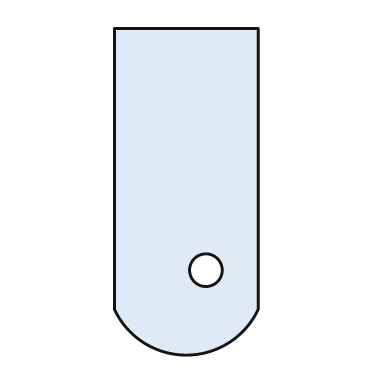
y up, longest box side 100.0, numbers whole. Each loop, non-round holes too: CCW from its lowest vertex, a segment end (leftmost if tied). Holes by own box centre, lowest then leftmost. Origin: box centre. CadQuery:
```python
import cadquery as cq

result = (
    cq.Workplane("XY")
    .moveTo(-22.0, -36.0)
    .threePointArc((0.0, -50.0), (22.0, -36.0))
    .lineTo(22.0, 50.0)
    .lineTo(-22.0, 50.0)
    .close()
    .moveTo(6.0, -24.0)
    .circle(5.0)
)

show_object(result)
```